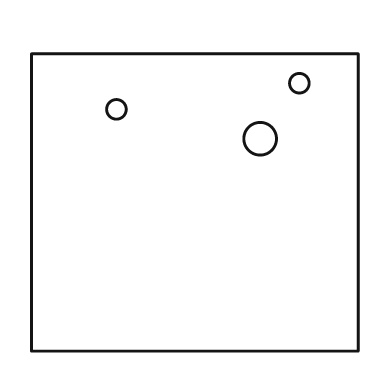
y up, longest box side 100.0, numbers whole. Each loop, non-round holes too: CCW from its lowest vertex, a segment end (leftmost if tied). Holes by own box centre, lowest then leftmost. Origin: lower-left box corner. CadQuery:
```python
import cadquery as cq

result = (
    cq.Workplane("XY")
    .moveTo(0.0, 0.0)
    .lineTo(100.0, 0.0)
    .lineTo(100.0, 91.0)
    .lineTo(0.0, 91.0)
    .close()
    .moveTo(70.0, 65.0)
    .circle(5.0)
    .moveTo(26.0, 74.0)
    .circle(3.0)
    .moveTo(82.0, 82.0)
    .circle(3.0)
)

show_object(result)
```